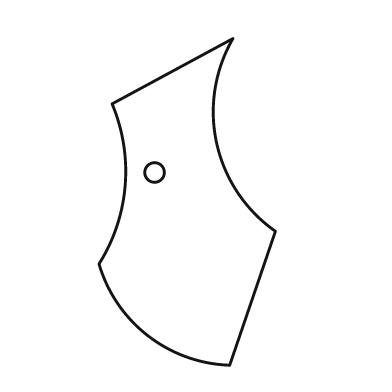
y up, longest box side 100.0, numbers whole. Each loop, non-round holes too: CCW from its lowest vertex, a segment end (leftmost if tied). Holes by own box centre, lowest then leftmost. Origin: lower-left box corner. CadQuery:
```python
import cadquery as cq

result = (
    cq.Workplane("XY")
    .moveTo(40.0, 0.0)
    .lineTo(54.0, 41.0)
    .threePointArc((36.0, 68.0), (41.0, 100.0))
    .lineTo(4.0, 80.0)
    .threePointArc((8.0, 55.0), (0.0, 31.0))
    .threePointArc((15.0, 9.0), (40.0, 0.0))
    .close()
    .moveTo(17.0, 59.0)
    .circle(3.0)
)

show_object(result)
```